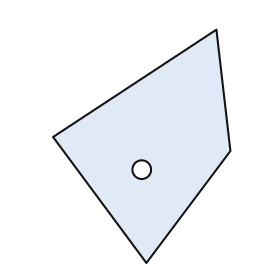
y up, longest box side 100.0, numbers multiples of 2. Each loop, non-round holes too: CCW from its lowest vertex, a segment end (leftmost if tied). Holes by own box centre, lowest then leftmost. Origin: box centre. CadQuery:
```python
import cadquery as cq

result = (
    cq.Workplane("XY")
    .moveTo(2.0, -50.0)
    .lineTo(38.0, -2.0)
    .lineTo(32.0, 50.0)
    .lineTo(-38.0, 4.0)
    .close()
    .moveTo(0.0, -10.0)
    .circle(4.0)
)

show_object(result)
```